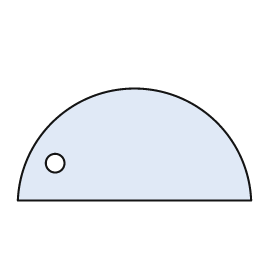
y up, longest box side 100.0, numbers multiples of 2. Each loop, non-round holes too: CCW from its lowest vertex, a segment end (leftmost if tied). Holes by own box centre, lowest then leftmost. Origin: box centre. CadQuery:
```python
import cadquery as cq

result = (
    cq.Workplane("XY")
    .moveTo(-50.0, -24.0)
    .lineTo(50.0, -24.0)
    .threePointArc((0.0, 24.0), (-50.0, -24.0))
    .close()
    .moveTo(-34.0, -8.0)
    .circle(4.0)
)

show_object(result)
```